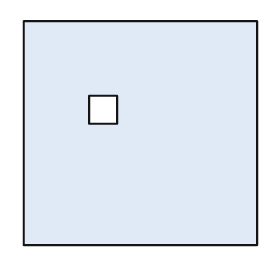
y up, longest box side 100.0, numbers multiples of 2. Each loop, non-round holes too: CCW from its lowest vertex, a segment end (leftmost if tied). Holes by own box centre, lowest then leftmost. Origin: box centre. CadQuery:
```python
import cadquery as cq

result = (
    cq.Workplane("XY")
    .moveTo(-50.0, -48.0)
    .lineTo(50.0, -48.0)
    .lineTo(50.0, 48.0)
    .lineTo(-50.0, 48.0)
    .close()
    .moveTo(-22.0, 4.0)
    .lineTo(-10.0, 4.0)
    .lineTo(-10.0, 16.0)
    .lineTo(-22.0, 16.0)
    .close()
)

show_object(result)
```